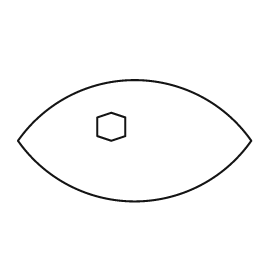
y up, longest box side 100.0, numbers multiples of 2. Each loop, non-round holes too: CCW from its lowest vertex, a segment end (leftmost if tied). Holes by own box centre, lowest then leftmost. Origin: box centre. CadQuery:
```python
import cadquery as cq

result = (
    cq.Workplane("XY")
    .moveTo(-50.0, 0.0)
    .threePointArc((0.0, -26.0), (50.0, 0.0))
    .threePointArc((0.0, 26.0), (-50.0, 0.0))
    .close()
    .moveTo(-10.0, 0.0)
    .lineTo(-4.0, 2.0)
    .lineTo(-4.0, 10.0)
    .lineTo(-10.0, 12.0)
    .lineTo(-16.0, 10.0)
    .lineTo(-16.0, 2.0)
    .close()
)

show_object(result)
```